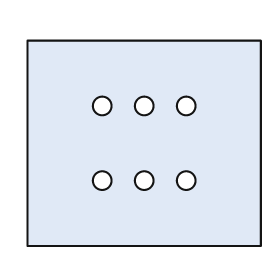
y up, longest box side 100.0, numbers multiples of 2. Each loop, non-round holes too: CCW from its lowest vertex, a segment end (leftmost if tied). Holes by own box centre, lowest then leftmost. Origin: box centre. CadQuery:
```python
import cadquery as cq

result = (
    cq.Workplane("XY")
    .moveTo(-50.0, -44.0)
    .lineTo(50.0, -44.0)
    .lineTo(50.0, 44.0)
    .lineTo(-50.0, 44.0)
    .close()
    .moveTo(-18.0, -16.0)
    .circle(4.0)
    .moveTo(0.0, -16.0)
    .circle(4.0)
    .moveTo(18.0, -16.0)
    .circle(4.0)
    .moveTo(-18.0, 16.0)
    .circle(4.0)
    .moveTo(0.0, 16.0)
    .circle(4.0)
    .moveTo(18.0, 16.0)
    .circle(4.0)
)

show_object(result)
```